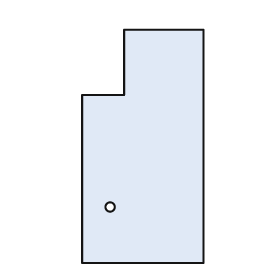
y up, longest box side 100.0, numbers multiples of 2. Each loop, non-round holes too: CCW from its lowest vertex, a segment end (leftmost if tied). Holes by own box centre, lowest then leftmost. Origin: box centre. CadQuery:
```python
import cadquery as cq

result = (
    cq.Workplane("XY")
    .moveTo(-26.0, -50.0)
    .lineTo(26.0, -50.0)
    .lineTo(26.0, 50.0)
    .lineTo(-8.0, 50.0)
    .lineTo(-8.0, 22.0)
    .lineTo(-26.0, 22.0)
    .close()
    .moveTo(-14.0, -26.0)
    .circle(2.0)
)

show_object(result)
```